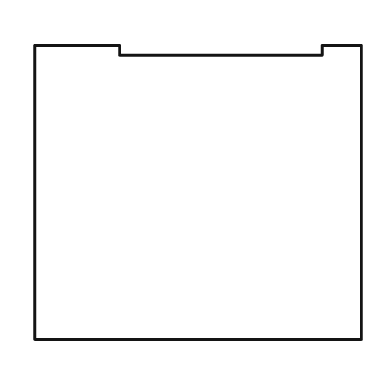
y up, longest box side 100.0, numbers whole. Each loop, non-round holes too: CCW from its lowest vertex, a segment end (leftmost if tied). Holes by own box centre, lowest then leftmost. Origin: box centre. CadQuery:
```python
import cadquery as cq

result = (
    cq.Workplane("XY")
    .moveTo(-50.0, -45.0)
    .lineTo(50.0, -45.0)
    .lineTo(50.0, 45.0)
    .lineTo(38.0, 45.0)
    .lineTo(38.0, 42.0)
    .lineTo(-24.0, 42.0)
    .lineTo(-24.0, 45.0)
    .lineTo(-50.0, 45.0)
    .close()
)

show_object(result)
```